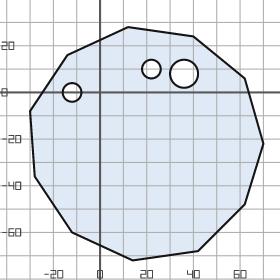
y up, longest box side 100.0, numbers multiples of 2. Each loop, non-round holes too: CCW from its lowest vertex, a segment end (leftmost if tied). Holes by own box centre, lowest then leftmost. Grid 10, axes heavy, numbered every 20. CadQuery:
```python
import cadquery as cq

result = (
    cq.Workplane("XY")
    .moveTo(14.0, -72.0)
    .lineTo(42.0, -68.0)
    .lineTo(62.0, -48.0)
    .lineTo(70.0, -22.0)
    .lineTo(62.0, 6.0)
    .lineTo(40.0, 24.0)
    .lineTo(12.0, 28.0)
    .lineTo(-14.0, 16.0)
    .lineTo(-30.0, -8.0)
    .lineTo(-28.0, -36.0)
    .lineTo(-12.0, -60.0)
    .close()
    .moveTo(-12.0, 0.0)
    .circle(4.0)
    .moveTo(36.0, 8.0)
    .circle(6.0)
    .moveTo(22.0, 10.0)
    .circle(4.0)
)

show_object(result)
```